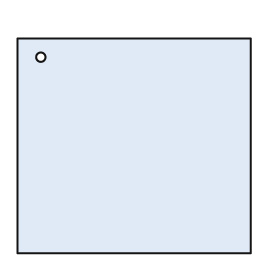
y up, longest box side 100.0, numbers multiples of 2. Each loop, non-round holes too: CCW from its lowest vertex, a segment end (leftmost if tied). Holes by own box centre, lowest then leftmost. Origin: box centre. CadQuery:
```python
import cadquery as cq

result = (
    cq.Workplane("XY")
    .moveTo(-50.0, -46.0)
    .lineTo(50.0, -46.0)
    .lineTo(50.0, 46.0)
    .lineTo(-50.0, 46.0)
    .close()
    .moveTo(-40.0, 38.0)
    .circle(2.0)
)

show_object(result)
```